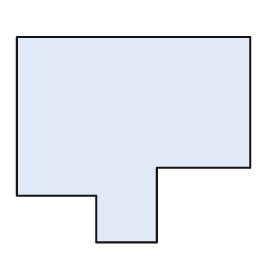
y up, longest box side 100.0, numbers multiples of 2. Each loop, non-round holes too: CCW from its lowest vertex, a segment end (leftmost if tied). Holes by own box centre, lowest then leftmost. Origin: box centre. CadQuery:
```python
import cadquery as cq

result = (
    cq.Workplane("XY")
    .moveTo(-16.0, -44.0)
    .lineTo(10.0, -44.0)
    .lineTo(10.0, -12.0)
    .lineTo(50.0, -12.0)
    .lineTo(50.0, 44.0)
    .lineTo(-50.0, 44.0)
    .lineTo(-50.0, -24.0)
    .lineTo(-16.0, -24.0)
    .close()
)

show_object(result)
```